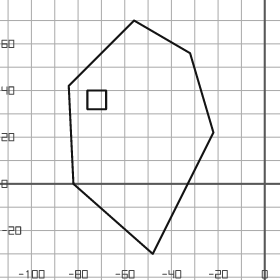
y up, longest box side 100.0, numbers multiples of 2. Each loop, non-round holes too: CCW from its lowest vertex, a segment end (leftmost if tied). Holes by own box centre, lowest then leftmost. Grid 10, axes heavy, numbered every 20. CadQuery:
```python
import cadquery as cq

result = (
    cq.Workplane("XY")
    .moveTo(-48.0, -30.0)
    .lineTo(-22.0, 22.0)
    .lineTo(-32.0, 56.0)
    .lineTo(-56.0, 70.0)
    .lineTo(-84.0, 42.0)
    .lineTo(-82.0, 0.0)
    .close()
    .moveTo(-76.0, 32.0)
    .lineTo(-68.0, 32.0)
    .lineTo(-68.0, 40.0)
    .lineTo(-76.0, 40.0)
    .close()
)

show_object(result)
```